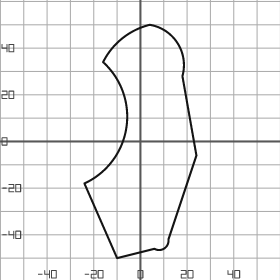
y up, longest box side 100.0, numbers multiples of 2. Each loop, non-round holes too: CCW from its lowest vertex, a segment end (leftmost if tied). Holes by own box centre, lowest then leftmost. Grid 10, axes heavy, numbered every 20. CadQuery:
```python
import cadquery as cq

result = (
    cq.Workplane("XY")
    .moveTo(-10.0, -50.0)
    .lineTo(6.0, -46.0)
    .threePointArc((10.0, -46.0), (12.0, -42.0))
    .lineTo(24.0, -6.0)
    .lineTo(18.0, 28.0)
    .threePointArc((16.0, 42.0), (4.0, 50.0))
    .threePointArc((-8.0, 44.0), (-16.0, 34.0))
    .threePointArc((-6.0, 6.0), (-24.0, -18.0))
    .close()
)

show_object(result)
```